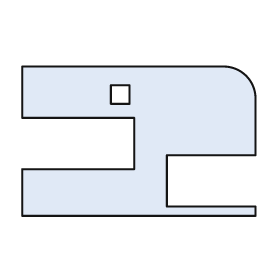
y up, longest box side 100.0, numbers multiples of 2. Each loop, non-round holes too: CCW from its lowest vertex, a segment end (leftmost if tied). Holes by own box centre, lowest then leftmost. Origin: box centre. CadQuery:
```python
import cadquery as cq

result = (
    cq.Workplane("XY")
    .moveTo(-50.0, -32.0)
    .lineTo(50.0, -32.0)
    .lineTo(50.0, -28.0)
    .lineTo(12.0, -28.0)
    .lineTo(12.0, -6.0)
    .lineTo(50.0, -6.0)
    .lineTo(50.0, 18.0)
    .threePointArc((46.0, 28.0), (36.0, 32.0))
    .lineTo(-50.0, 32.0)
    .lineTo(-50.0, 10.0)
    .lineTo(-2.0, 10.0)
    .lineTo(-2.0, -12.0)
    .lineTo(-50.0, -12.0)
    .close()
    .moveTo(-12.0, 16.0)
    .lineTo(-4.0, 16.0)
    .lineTo(-4.0, 24.0)
    .lineTo(-12.0, 24.0)
    .close()
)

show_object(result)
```